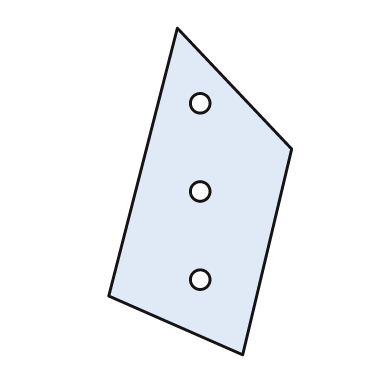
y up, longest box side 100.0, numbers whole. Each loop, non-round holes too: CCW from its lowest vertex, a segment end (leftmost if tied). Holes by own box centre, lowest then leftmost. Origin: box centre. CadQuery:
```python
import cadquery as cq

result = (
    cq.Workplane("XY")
    .moveTo(13.0, -50.0)
    .lineTo(28.0, 13.0)
    .lineTo(-7.0, 50.0)
    .lineTo(-28.0, -32.0)
    .close()
    .moveTo(0.0, -27.0)
    .circle(3.0)
    .moveTo(0.0, 0.0)
    .circle(3.0)
    .moveTo(0.0, 27.0)
    .circle(3.0)
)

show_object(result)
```